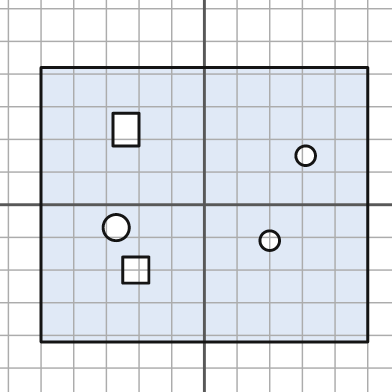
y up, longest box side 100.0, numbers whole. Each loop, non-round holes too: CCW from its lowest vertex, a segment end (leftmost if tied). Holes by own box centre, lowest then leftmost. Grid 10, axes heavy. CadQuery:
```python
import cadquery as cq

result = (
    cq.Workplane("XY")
    .moveTo(-50.0, -42.0)
    .lineTo(50.0, -42.0)
    .lineTo(50.0, 42.0)
    .lineTo(-50.0, 42.0)
    .close()
    .moveTo(-25.0, -24.0)
    .lineTo(-17.0, -24.0)
    .lineTo(-17.0, -16.0)
    .lineTo(-25.0, -16.0)
    .close()
    .moveTo(20.0, -11.0)
    .circle(3.0)
    .moveTo(-27.0, -7.0)
    .circle(4.0)
    .moveTo(31.0, 15.0)
    .circle(3.0)
    .moveTo(-28.0, 18.0)
    .lineTo(-20.0, 18.0)
    .lineTo(-20.0, 28.0)
    .lineTo(-28.0, 28.0)
    .close()
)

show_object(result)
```